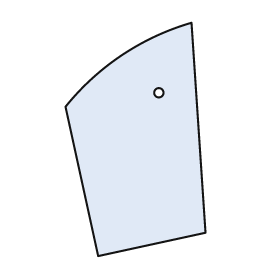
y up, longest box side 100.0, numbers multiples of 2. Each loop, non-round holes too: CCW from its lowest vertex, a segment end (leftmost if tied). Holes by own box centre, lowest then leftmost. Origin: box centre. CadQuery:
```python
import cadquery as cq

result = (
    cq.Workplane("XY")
    .moveTo(-16.0, -50.0)
    .lineTo(30.0, -40.0)
    .lineTo(24.0, 50.0)
    .threePointArc((-6.0, 36.0), (-30.0, 14.0))
    .close()
    .moveTo(10.0, 20.0)
    .circle(2.0)
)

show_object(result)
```